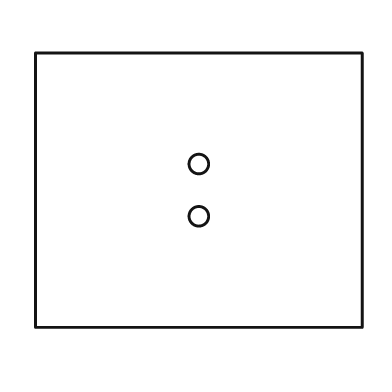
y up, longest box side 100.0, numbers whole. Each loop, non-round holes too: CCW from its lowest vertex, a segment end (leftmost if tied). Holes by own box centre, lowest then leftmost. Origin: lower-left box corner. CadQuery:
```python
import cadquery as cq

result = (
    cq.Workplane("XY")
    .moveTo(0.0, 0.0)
    .lineTo(100.0, 0.0)
    .lineTo(100.0, 84.0)
    .lineTo(0.0, 84.0)
    .close()
    .moveTo(50.0, 34.0)
    .circle(3.0)
    .moveTo(50.0, 50.0)
    .circle(3.0)
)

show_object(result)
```